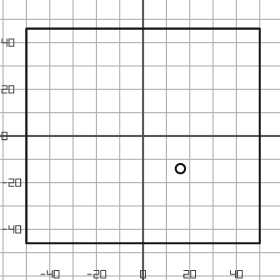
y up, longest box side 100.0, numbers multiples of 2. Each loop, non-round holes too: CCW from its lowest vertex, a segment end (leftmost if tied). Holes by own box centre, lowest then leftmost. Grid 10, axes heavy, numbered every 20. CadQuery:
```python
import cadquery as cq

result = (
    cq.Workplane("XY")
    .moveTo(-50.0, -46.0)
    .lineTo(50.0, -46.0)
    .lineTo(50.0, 46.0)
    .lineTo(-50.0, 46.0)
    .close()
    .moveTo(16.0, -14.0)
    .circle(2.0)
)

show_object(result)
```